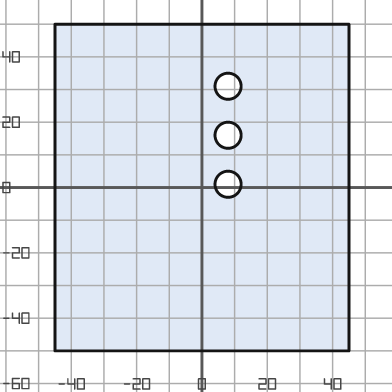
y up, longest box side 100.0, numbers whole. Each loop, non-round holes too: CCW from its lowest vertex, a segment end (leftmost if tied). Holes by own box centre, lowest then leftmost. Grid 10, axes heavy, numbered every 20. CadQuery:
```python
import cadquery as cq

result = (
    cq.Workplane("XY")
    .moveTo(-45.0, -50.0)
    .lineTo(45.0, -50.0)
    .lineTo(45.0, 50.0)
    .lineTo(-45.0, 50.0)
    .close()
    .moveTo(8.0, 1.0)
    .circle(4.0)
    .moveTo(8.0, 16.0)
    .circle(4.0)
    .moveTo(8.0, 31.0)
    .circle(4.0)
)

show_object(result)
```